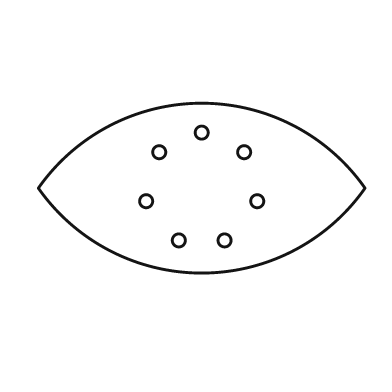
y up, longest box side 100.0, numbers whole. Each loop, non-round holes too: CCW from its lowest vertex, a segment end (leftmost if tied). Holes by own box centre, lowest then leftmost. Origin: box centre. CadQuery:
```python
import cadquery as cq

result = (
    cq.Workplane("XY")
    .moveTo(-50.0, 0.0)
    .threePointArc((0.0, -26.0), (50.0, 0.0))
    .threePointArc((0.0, 26.0), (-50.0, 0.0))
    .close()
    .moveTo(-7.0, -16.0)
    .circle(2.0)
    .moveTo(7.0, -16.0)
    .circle(2.0)
    .moveTo(-17.0, -4.0)
    .circle(2.0)
    .moveTo(17.0, -4.0)
    .circle(2.0)
    .moveTo(-13.0, 11.0)
    .circle(2.0)
    .moveTo(13.0, 11.0)
    .circle(2.0)
    .moveTo(0.0, 17.0)
    .circle(2.0)
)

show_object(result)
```